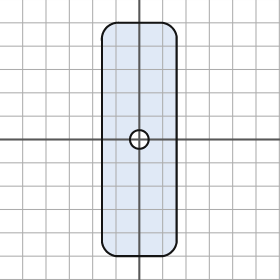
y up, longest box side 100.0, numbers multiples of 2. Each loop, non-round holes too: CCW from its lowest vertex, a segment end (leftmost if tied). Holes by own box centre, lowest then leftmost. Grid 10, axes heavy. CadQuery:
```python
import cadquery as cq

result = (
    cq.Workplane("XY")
    .moveTo(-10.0, -50.0)
    .lineTo(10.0, -50.0)
    .threePointArc((14.0, -48.0), (16.0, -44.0))
    .lineTo(16.0, 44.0)
    .threePointArc((14.0, 48.0), (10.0, 50.0))
    .lineTo(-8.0, 50.0)
    .threePointArc((-14.0, 48.0), (-16.0, 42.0))
    .lineTo(-16.0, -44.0)
    .threePointArc((-14.0, -48.0), (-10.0, -50.0))
    .close()
    .moveTo(0.0, 0.0)
    .circle(4.0)
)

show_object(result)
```